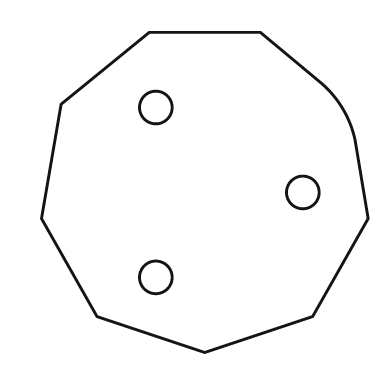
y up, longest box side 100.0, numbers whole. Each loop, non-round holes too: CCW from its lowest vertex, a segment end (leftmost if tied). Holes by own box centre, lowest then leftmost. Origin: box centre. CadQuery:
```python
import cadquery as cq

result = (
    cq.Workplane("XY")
    .moveTo(0.0, -49.0)
    .lineTo(33.0, -38.0)
    .lineTo(50.0, -8.0)
    .lineTo(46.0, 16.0)
    .threePointArc((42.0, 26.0), (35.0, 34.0))
    .lineTo(17.0, 49.0)
    .lineTo(-17.0, 49.0)
    .lineTo(-44.0, 27.0)
    .lineTo(-50.0, -8.0)
    .lineTo(-33.0, -38.0)
    .close()
    .moveTo(-15.0, -26.0)
    .circle(5.0)
    .moveTo(30.0, 0.0)
    .circle(5.0)
    .moveTo(-15.0, 26.0)
    .circle(5.0)
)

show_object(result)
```